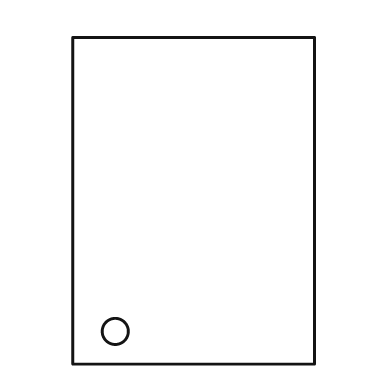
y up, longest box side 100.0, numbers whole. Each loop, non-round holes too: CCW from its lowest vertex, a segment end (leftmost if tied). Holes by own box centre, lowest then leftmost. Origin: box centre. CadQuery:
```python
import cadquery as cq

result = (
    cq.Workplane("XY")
    .moveTo(-37.0, -50.0)
    .lineTo(37.0, -50.0)
    .lineTo(37.0, 50.0)
    .lineTo(-37.0, 50.0)
    .close()
    .moveTo(-24.0, -40.0)
    .circle(4.0)
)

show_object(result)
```